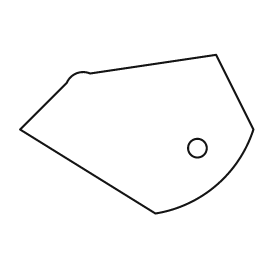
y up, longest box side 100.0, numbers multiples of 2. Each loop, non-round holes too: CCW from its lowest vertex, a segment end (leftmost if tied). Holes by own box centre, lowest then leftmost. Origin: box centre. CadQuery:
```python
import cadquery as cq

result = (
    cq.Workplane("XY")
    .moveTo(8.0, -34.0)
    .threePointArc((34.0, -22.0), (50.0, 2.0))
    .lineTo(34.0, 34.0)
    .lineTo(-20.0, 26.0)
    .threePointArc((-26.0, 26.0), (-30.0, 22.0))
    .lineTo(-50.0, 2.0)
    .close()
    .moveTo(26.0, -6.0)
    .circle(4.0)
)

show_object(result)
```